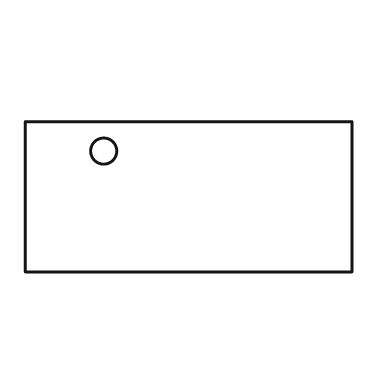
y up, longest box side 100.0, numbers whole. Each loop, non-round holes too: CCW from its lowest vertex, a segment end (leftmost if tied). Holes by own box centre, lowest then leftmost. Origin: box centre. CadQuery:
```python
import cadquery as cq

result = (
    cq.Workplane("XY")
    .moveTo(-50.0, -23.0)
    .lineTo(50.0, -23.0)
    .lineTo(50.0, 23.0)
    .lineTo(-50.0, 23.0)
    .close()
    .moveTo(-26.0, 14.0)
    .circle(4.0)
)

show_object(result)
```